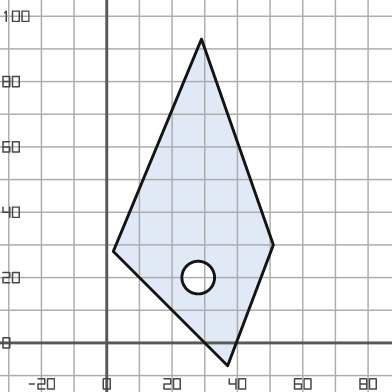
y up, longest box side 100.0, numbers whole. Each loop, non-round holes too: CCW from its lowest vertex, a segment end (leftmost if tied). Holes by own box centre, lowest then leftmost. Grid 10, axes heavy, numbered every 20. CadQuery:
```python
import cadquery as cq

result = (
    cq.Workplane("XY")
    .moveTo(37.0, -7.0)
    .lineTo(51.0, 30.0)
    .lineTo(29.0, 93.0)
    .lineTo(2.0, 28.0)
    .close()
    .moveTo(28.0, 20.0)
    .circle(5.0)
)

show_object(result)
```